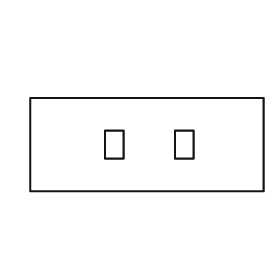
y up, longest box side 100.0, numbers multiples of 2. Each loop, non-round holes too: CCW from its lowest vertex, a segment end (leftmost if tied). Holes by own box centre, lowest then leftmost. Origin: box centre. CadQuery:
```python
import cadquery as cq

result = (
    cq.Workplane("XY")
    .moveTo(-50.0, -20.0)
    .lineTo(50.0, -20.0)
    .lineTo(50.0, 20.0)
    .lineTo(-50.0, 20.0)
    .close()
    .moveTo(-18.0, -6.0)
    .lineTo(-10.0, -6.0)
    .lineTo(-10.0, 6.0)
    .lineTo(-18.0, 6.0)
    .close()
    .moveTo(12.0, -6.0)
    .lineTo(20.0, -6.0)
    .lineTo(20.0, 6.0)
    .lineTo(12.0, 6.0)
    .close()
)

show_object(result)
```